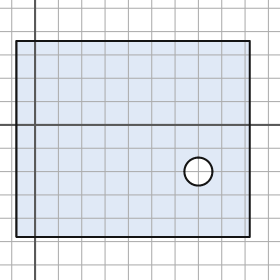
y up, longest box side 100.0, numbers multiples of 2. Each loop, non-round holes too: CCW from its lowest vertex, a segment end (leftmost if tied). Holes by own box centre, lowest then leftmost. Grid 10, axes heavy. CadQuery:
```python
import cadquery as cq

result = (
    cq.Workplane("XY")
    .moveTo(-8.0, -48.0)
    .lineTo(92.0, -48.0)
    .lineTo(92.0, 36.0)
    .lineTo(-8.0, 36.0)
    .close()
    .moveTo(70.0, -20.0)
    .circle(6.0)
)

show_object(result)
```